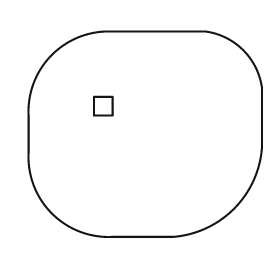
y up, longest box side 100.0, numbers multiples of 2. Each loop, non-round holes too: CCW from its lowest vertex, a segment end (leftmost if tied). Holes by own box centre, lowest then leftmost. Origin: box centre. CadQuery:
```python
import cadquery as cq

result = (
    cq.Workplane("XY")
    .moveTo(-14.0, -44.0)
    .lineTo(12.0, -44.0)
    .threePointArc((38.0, -32.0), (50.0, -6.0))
    .lineTo(50.0, 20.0)
    .threePointArc((42.0, 36.0), (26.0, 44.0))
    .lineTo(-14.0, 44.0)
    .threePointArc((-40.0, 34.0), (-50.0, 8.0))
    .lineTo(-50.0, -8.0)
    .threePointArc((-40.0, -34.0), (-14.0, -44.0))
    .close()
    .moveTo(-22.0, 8.0)
    .lineTo(-14.0, 8.0)
    .lineTo(-14.0, 16.0)
    .lineTo(-22.0, 16.0)
    .close()
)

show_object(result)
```